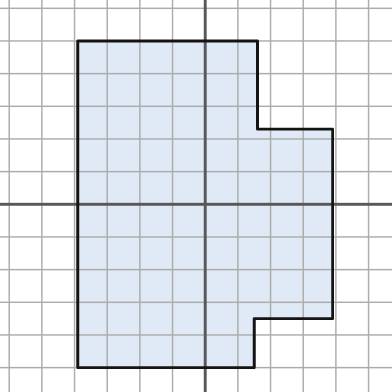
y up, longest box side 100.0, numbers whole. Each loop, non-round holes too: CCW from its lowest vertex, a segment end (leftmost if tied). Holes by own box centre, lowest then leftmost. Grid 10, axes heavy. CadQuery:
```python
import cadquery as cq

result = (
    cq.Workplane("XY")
    .moveTo(-39.0, -50.0)
    .lineTo(15.0, -50.0)
    .lineTo(15.0, -35.0)
    .lineTo(39.0, -35.0)
    .lineTo(39.0, 23.0)
    .lineTo(16.0, 23.0)
    .lineTo(16.0, 50.0)
    .lineTo(-39.0, 50.0)
    .close()
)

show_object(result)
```